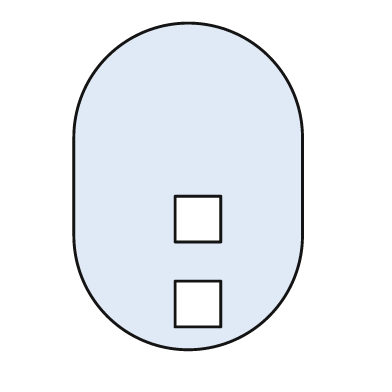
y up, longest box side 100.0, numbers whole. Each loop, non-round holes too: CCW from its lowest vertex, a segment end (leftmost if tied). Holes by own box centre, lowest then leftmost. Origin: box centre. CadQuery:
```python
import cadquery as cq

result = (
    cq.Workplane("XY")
    .moveTo(-35.0, -15.0)
    .threePointArc((0.0, -50.0), (35.0, -15.0))
    .lineTo(35.0, 15.0)
    .threePointArc((0.0, 50.0), (-35.0, 15.0))
    .close()
    .moveTo(-4.0, -43.0)
    .lineTo(10.0, -43.0)
    .lineTo(10.0, -29.0)
    .lineTo(-4.0, -29.0)
    .close()
    .moveTo(-4.0, -17.0)
    .lineTo(10.0, -17.0)
    .lineTo(10.0, -3.0)
    .lineTo(-4.0, -3.0)
    .close()
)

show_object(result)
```